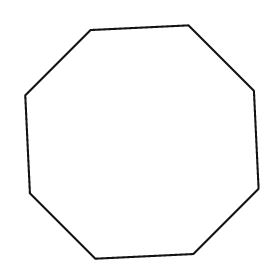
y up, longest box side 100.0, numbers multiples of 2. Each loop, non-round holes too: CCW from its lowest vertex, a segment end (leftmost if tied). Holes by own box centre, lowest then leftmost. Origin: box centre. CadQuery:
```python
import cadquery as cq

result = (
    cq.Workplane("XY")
    .moveTo(-20.0, -50.0)
    .lineTo(22.0, -48.0)
    .lineTo(50.0, -20.0)
    .lineTo(48.0, 22.0)
    .lineTo(20.0, 50.0)
    .lineTo(-22.0, 48.0)
    .lineTo(-50.0, 20.0)
    .lineTo(-48.0, -22.0)
    .close()
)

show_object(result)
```